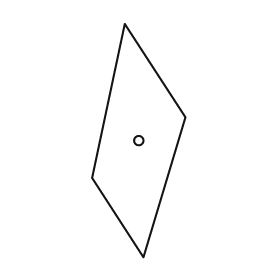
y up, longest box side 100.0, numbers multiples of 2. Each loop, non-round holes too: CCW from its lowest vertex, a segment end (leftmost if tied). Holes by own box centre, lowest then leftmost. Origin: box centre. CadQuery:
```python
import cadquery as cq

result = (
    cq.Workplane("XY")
    .moveTo(2.0, -50.0)
    .lineTo(20.0, 10.0)
    .lineTo(-6.0, 50.0)
    .lineTo(-20.0, -16.0)
    .close()
    .moveTo(0.0, 0.0)
    .circle(2.0)
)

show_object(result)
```